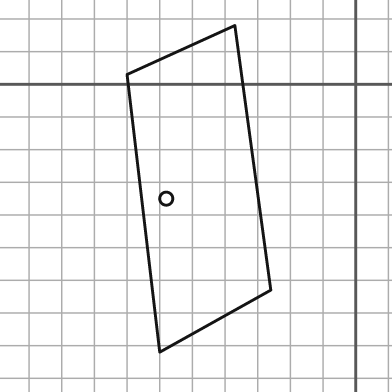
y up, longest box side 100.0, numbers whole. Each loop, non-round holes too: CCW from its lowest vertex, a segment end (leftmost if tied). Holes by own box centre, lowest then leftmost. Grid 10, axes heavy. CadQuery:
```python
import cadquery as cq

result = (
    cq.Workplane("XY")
    .moveTo(-60.0, -82.0)
    .lineTo(-26.0, -63.0)
    .lineTo(-37.0, 18.0)
    .lineTo(-70.0, 3.0)
    .close()
    .moveTo(-58.0, -35.0)
    .circle(2.0)
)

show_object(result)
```